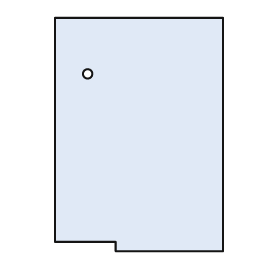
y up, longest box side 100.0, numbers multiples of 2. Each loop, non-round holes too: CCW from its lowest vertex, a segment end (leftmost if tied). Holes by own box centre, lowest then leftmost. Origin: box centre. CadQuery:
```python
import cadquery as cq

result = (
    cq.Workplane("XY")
    .moveTo(-10.0, -50.0)
    .lineTo(36.0, -50.0)
    .lineTo(36.0, 50.0)
    .lineTo(-36.0, 50.0)
    .lineTo(-36.0, -46.0)
    .lineTo(-10.0, -46.0)
    .close()
    .moveTo(-22.0, 26.0)
    .circle(2.0)
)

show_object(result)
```